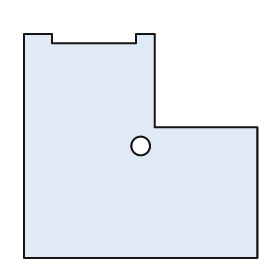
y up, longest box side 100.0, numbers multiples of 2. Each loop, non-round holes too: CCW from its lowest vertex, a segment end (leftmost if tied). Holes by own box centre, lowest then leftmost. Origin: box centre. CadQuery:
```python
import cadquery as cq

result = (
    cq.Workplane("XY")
    .moveTo(-50.0, -48.0)
    .lineTo(50.0, -48.0)
    .lineTo(50.0, 8.0)
    .lineTo(6.0, 8.0)
    .lineTo(6.0, 48.0)
    .lineTo(-2.0, 48.0)
    .lineTo(-2.0, 44.0)
    .lineTo(-38.0, 44.0)
    .lineTo(-38.0, 48.0)
    .lineTo(-50.0, 48.0)
    .close()
    .moveTo(0.0, 0.0)
    .circle(4.0)
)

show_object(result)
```